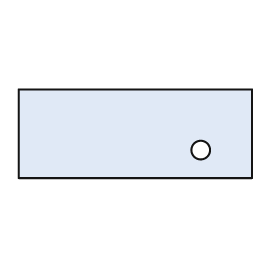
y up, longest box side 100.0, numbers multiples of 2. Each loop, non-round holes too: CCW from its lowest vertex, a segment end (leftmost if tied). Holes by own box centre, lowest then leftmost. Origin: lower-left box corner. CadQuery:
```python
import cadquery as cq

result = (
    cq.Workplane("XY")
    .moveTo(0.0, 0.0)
    .lineTo(100.0, 0.0)
    .lineTo(100.0, 38.0)
    .lineTo(0.0, 38.0)
    .close()
    .moveTo(78.0, 12.0)
    .circle(4.0)
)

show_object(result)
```